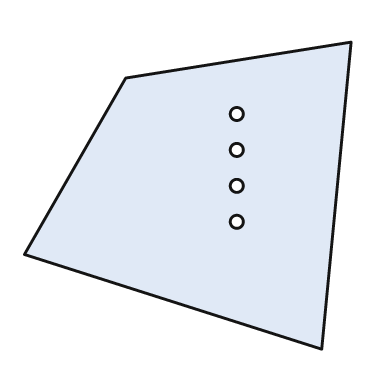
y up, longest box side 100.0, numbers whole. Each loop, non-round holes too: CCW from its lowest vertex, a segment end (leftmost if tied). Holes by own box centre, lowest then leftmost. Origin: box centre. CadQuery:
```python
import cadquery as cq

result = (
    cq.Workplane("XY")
    .moveTo(41.0, -47.0)
    .lineTo(50.0, 47.0)
    .lineTo(-19.0, 36.0)
    .lineTo(-50.0, -18.0)
    .close()
    .moveTo(15.0, -8.0)
    .circle(2.0)
    .moveTo(15.0, 3.0)
    .circle(2.0)
    .moveTo(15.0, 14.0)
    .circle(2.0)
    .moveTo(15.0, 25.0)
    .circle(2.0)
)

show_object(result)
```